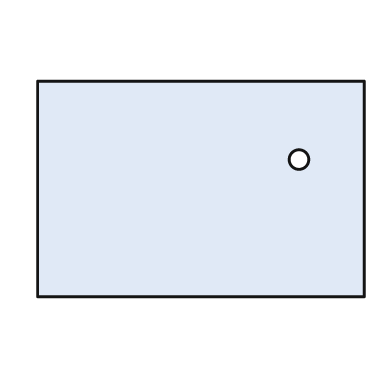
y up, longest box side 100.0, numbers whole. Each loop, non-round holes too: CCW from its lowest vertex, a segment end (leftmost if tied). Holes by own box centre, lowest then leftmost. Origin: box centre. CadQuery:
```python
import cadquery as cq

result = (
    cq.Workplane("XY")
    .moveTo(-50.0, -33.0)
    .lineTo(50.0, -33.0)
    .lineTo(50.0, 33.0)
    .lineTo(-50.0, 33.0)
    .close()
    .moveTo(30.0, 9.0)
    .circle(3.0)
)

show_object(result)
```